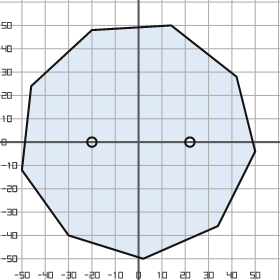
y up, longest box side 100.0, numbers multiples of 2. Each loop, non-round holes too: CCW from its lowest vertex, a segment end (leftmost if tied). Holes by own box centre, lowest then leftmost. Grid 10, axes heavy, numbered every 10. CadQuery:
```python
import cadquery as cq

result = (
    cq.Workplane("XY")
    .moveTo(2.0, -50.0)
    .lineTo(34.0, -36.0)
    .lineTo(50.0, -4.0)
    .lineTo(42.0, 28.0)
    .lineTo(14.0, 50.0)
    .lineTo(-20.0, 48.0)
    .lineTo(-46.0, 24.0)
    .lineTo(-50.0, -12.0)
    .lineTo(-30.0, -40.0)
    .close()
    .moveTo(-20.0, 0.0)
    .circle(2.0)
    .moveTo(22.0, 0.0)
    .circle(2.0)
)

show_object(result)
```